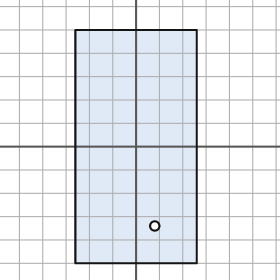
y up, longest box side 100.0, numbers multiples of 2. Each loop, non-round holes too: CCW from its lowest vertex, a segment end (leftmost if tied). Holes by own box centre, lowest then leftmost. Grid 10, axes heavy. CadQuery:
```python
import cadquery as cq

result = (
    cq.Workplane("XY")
    .moveTo(-26.0, -50.0)
    .lineTo(26.0, -50.0)
    .lineTo(26.0, 50.0)
    .lineTo(-26.0, 50.0)
    .close()
    .moveTo(8.0, -34.0)
    .circle(2.0)
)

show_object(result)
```